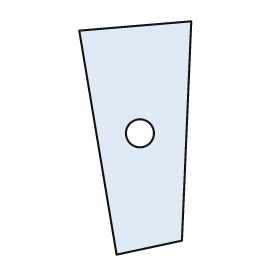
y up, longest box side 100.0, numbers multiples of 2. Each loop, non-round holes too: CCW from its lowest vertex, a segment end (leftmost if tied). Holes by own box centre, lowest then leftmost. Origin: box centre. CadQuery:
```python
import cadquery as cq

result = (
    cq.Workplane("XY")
    .moveTo(-8.0, -50.0)
    .lineTo(20.0, -44.0)
    .lineTo(24.0, 50.0)
    .lineTo(-24.0, 46.0)
    .close()
    .moveTo(2.0, 2.0)
    .circle(6.0)
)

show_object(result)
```